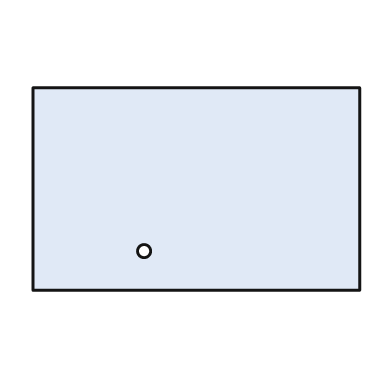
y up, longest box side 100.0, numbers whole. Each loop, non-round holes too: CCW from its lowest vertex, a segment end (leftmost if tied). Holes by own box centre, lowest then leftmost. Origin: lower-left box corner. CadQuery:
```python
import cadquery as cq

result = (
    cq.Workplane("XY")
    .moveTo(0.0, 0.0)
    .lineTo(100.0, 0.0)
    .lineTo(100.0, 62.0)
    .lineTo(0.0, 62.0)
    .close()
    .moveTo(34.0, 12.0)
    .circle(2.0)
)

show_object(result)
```